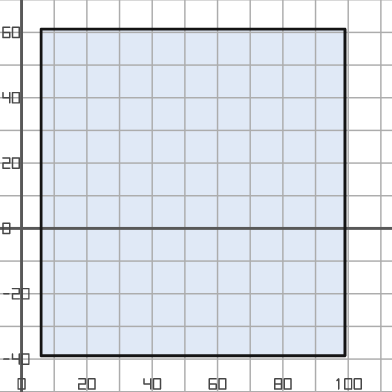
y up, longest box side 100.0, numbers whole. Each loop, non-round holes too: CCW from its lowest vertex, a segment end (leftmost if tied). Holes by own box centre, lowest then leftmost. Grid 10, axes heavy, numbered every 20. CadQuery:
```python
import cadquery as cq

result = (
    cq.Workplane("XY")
    .moveTo(6.0, -39.0)
    .lineTo(99.0, -39.0)
    .lineTo(99.0, 61.0)
    .lineTo(6.0, 61.0)
    .close()
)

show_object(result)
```